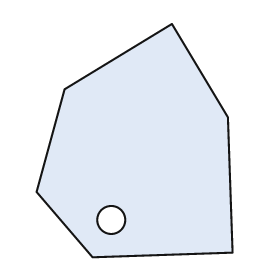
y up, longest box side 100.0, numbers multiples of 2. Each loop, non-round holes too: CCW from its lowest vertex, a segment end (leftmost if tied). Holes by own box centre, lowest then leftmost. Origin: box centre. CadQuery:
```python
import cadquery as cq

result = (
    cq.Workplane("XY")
    .moveTo(-18.0, -50.0)
    .lineTo(42.0, -48.0)
    .lineTo(40.0, 10.0)
    .lineTo(16.0, 50.0)
    .lineTo(-30.0, 22.0)
    .lineTo(-42.0, -22.0)
    .close()
    .moveTo(-10.0, -34.0)
    .circle(6.0)
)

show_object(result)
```